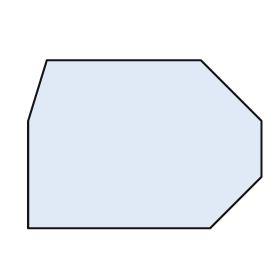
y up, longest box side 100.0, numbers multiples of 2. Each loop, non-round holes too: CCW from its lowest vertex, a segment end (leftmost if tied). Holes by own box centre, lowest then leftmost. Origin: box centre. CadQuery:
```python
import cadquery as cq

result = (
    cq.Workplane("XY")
    .moveTo(-50.0, -36.0)
    .lineTo(28.0, -36.0)
    .lineTo(50.0, -14.0)
    .lineTo(50.0, 10.0)
    .lineTo(24.0, 36.0)
    .lineTo(-42.0, 36.0)
    .lineTo(-50.0, 10.0)
    .close()
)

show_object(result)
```